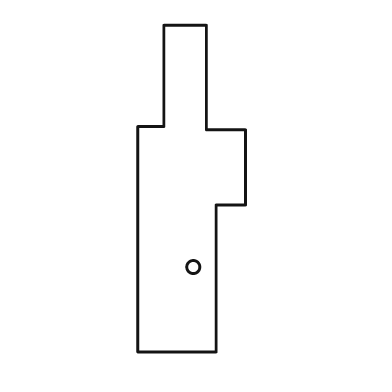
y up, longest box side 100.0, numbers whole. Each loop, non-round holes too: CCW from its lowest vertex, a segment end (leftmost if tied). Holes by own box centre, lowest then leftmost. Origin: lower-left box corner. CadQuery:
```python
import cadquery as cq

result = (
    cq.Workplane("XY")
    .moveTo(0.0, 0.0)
    .lineTo(24.0, 0.0)
    .lineTo(24.0, 45.0)
    .lineTo(33.0, 45.0)
    .lineTo(33.0, 68.0)
    .lineTo(21.0, 68.0)
    .lineTo(21.0, 100.0)
    .lineTo(8.0, 100.0)
    .lineTo(8.0, 69.0)
    .lineTo(0.0, 69.0)
    .close()
    .moveTo(17.0, 26.0)
    .circle(2.0)
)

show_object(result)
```